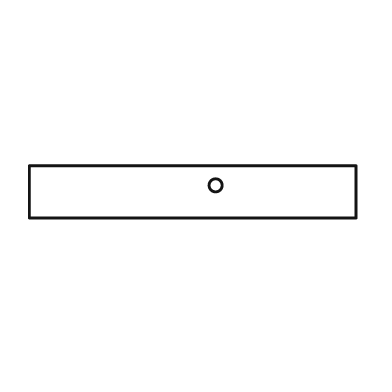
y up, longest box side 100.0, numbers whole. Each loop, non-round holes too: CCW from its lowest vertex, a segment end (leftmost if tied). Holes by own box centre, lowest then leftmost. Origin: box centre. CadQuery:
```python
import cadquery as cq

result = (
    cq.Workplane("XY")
    .moveTo(-50.0, -8.0)
    .lineTo(50.0, -8.0)
    .lineTo(50.0, 8.0)
    .lineTo(-50.0, 8.0)
    .close()
    .moveTo(7.0, 2.0)
    .circle(2.0)
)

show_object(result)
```